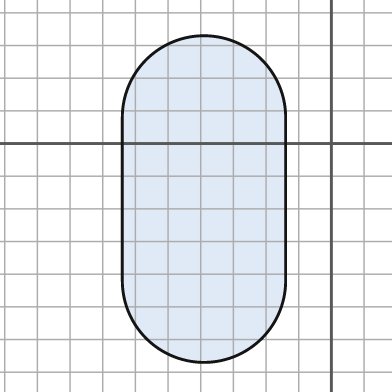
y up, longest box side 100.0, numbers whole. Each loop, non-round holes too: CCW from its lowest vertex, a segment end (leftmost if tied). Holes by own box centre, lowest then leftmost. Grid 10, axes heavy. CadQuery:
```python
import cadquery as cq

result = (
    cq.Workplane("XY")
    .moveTo(-64.0, -42.0)
    .threePointArc((-39.0, -67.0), (-14.0, -42.0))
    .lineTo(-14.0, 8.0)
    .threePointArc((-39.0, 33.0), (-64.0, 8.0))
    .close()
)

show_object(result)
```